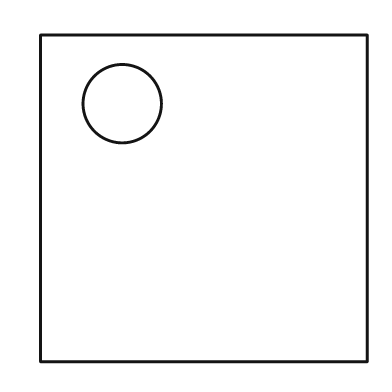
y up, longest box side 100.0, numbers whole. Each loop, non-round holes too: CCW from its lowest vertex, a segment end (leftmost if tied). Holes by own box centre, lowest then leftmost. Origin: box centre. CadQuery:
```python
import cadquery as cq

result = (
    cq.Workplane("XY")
    .moveTo(-50.0, -50.0)
    .lineTo(50.0, -50.0)
    .lineTo(50.0, 50.0)
    .lineTo(-50.0, 50.0)
    .close()
    .moveTo(-25.0, 29.0)
    .circle(12.0)
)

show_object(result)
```